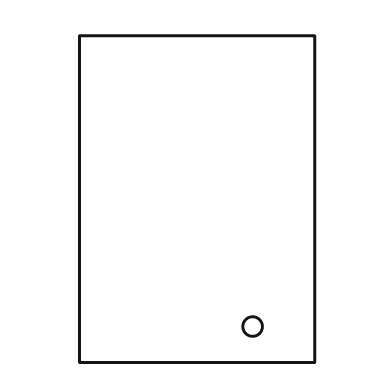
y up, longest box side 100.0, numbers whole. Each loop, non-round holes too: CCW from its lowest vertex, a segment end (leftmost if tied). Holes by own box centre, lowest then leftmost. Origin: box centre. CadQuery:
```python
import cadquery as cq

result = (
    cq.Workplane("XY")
    .moveTo(-36.0, -50.0)
    .lineTo(36.0, -50.0)
    .lineTo(36.0, 50.0)
    .lineTo(-36.0, 50.0)
    .close()
    .moveTo(17.0, -39.0)
    .circle(3.0)
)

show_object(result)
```